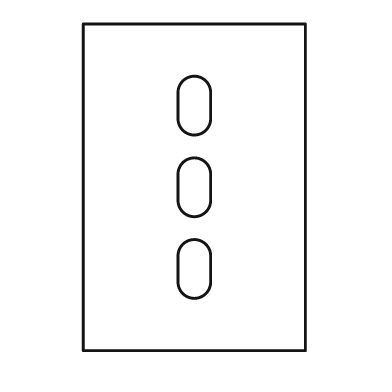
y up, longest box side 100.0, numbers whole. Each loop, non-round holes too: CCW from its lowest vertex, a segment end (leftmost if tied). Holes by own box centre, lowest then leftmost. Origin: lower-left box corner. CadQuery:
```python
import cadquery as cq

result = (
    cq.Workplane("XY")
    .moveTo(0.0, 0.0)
    .lineTo(68.0, 0.0)
    .lineTo(68.0, 100.0)
    .lineTo(0.0, 100.0)
    .close()
    .moveTo(29.0, 21.0)
    .threePointArc((34.0, 16.0), (39.0, 21.0))
    .lineTo(39.0, 29.0)
    .threePointArc((34.0, 34.0), (29.0, 29.0))
    .close()
    .moveTo(29.0, 46.0)
    .threePointArc((34.0, 41.0), (39.0, 46.0))
    .lineTo(39.0, 54.0)
    .threePointArc((34.0, 59.0), (29.0, 54.0))
    .close()
    .moveTo(29.0, 71.0)
    .threePointArc((34.0, 66.0), (39.0, 71.0))
    .lineTo(39.0, 79.0)
    .threePointArc((34.0, 84.0), (29.0, 79.0))
    .close()
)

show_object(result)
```